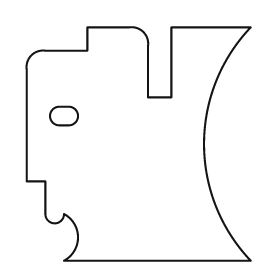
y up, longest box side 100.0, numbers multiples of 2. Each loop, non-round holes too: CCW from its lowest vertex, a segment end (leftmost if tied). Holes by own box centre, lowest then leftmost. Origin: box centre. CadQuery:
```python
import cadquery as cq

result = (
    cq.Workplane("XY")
    .moveTo(-32.0, -50.0)
    .lineTo(48.0, -50.0)
    .threePointArc((28.0, 0.0), (48.0, 50.0))
    .lineTo(14.0, 50.0)
    .lineTo(14.0, 20.0)
    .lineTo(4.0, 20.0)
    .lineTo(4.0, 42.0)
    .threePointArc((2.0, 48.0), (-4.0, 50.0))
    .lineTo(-22.0, 50.0)
    .lineTo(-22.0, 40.0)
    .lineTo(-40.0, 40.0)
    .threePointArc((-46.0, 38.0), (-48.0, 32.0))
    .lineTo(-48.0, -16.0)
    .lineTo(-40.0, -16.0)
    .lineTo(-40.0, -30.0)
    .threePointArc((-36.0, -34.0), (-32.0, -30.0))
    .threePointArc((-26.0, -40.0), (-32.0, -50.0))
    .close()
    .moveTo(-34.0, 8.0)
    .lineTo(-30.0, 8.0)
    .threePointArc((-26.0, 12.0), (-30.0, 16.0))
    .lineTo(-34.0, 16.0)
    .threePointArc((-38.0, 12.0), (-34.0, 8.0))
    .close()
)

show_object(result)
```